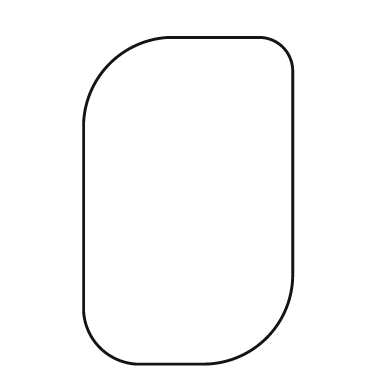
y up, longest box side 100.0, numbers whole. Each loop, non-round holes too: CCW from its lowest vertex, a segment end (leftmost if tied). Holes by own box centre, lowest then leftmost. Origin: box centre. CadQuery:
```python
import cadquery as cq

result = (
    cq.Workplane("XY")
    .moveTo(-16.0, -50.0)
    .lineTo(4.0, -50.0)
    .threePointArc((24.0, -42.0), (32.0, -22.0))
    .lineTo(32.0, 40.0)
    .threePointArc((29.0, 47.0), (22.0, 50.0))
    .lineTo(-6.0, 50.0)
    .threePointArc((-24.0, 42.0), (-32.0, 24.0))
    .lineTo(-32.0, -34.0)
    .threePointArc((-27.0, -45.0), (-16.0, -50.0))
    .close()
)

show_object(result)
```